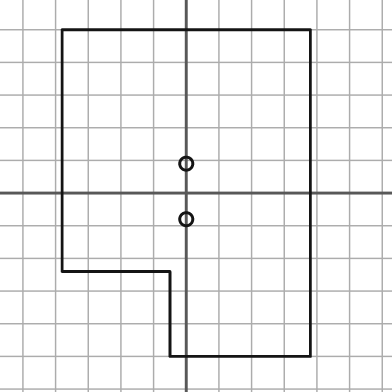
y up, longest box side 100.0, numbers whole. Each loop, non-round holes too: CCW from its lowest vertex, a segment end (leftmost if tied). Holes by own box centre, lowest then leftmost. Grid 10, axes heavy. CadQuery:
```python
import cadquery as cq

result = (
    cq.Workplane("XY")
    .moveTo(-5.0, -50.0)
    .lineTo(38.0, -50.0)
    .lineTo(38.0, 50.0)
    .lineTo(-38.0, 50.0)
    .lineTo(-38.0, -24.0)
    .lineTo(-5.0, -24.0)
    .close()
    .moveTo(0.0, -8.0)
    .circle(2.0)
    .moveTo(0.0, 9.0)
    .circle(2.0)
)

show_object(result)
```